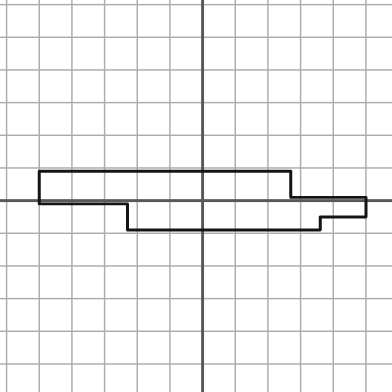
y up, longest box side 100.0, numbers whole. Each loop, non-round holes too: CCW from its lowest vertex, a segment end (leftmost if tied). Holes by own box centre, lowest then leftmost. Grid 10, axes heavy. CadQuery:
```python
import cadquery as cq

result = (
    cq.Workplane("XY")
    .moveTo(-23.0, -9.0)
    .lineTo(36.0, -9.0)
    .lineTo(36.0, -5.0)
    .lineTo(50.0, -5.0)
    .lineTo(50.0, 1.0)
    .lineTo(27.0, 1.0)
    .lineTo(27.0, 9.0)
    .lineTo(-50.0, 9.0)
    .lineTo(-50.0, -1.0)
    .lineTo(-23.0, -1.0)
    .close()
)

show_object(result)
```